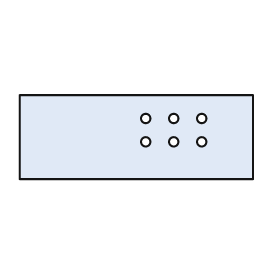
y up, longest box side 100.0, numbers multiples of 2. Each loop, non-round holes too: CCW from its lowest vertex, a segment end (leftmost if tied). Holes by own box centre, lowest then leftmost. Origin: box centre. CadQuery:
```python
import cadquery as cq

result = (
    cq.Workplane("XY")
    .moveTo(-50.0, -18.0)
    .lineTo(50.0, -18.0)
    .lineTo(50.0, 18.0)
    .lineTo(-50.0, 18.0)
    .close()
    .moveTo(4.0, -2.0)
    .circle(2.0)
    .moveTo(16.0, -2.0)
    .circle(2.0)
    .moveTo(28.0, -2.0)
    .circle(2.0)
    .moveTo(4.0, 8.0)
    .circle(2.0)
    .moveTo(16.0, 8.0)
    .circle(2.0)
    .moveTo(28.0, 8.0)
    .circle(2.0)
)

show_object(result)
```